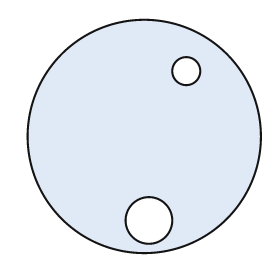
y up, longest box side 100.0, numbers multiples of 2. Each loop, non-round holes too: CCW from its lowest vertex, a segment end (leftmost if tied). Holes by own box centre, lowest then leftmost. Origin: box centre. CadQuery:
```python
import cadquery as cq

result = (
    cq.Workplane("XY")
    .moveTo(0.0, 0.0)
    .circle(50.0)
    .moveTo(2.0, -36.0)
    .circle(10.0)
    .moveTo(18.0, 28.0)
    .circle(6.0)
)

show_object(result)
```